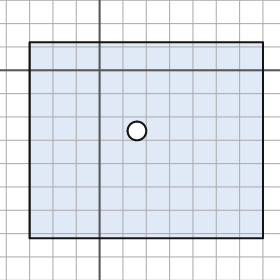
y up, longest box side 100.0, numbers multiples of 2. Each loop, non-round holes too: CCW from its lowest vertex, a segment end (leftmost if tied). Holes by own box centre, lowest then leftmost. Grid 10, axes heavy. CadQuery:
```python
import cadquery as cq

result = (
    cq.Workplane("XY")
    .moveTo(-30.0, -72.0)
    .lineTo(70.0, -72.0)
    .lineTo(70.0, 12.0)
    .lineTo(-30.0, 12.0)
    .close()
    .moveTo(16.0, -26.0)
    .circle(4.0)
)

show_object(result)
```